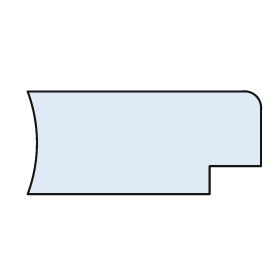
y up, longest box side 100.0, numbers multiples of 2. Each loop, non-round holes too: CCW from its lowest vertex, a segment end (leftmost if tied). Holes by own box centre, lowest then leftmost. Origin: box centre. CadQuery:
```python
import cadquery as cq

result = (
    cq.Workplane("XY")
    .moveTo(-50.0, -22.0)
    .lineTo(28.0, -22.0)
    .lineTo(28.0, -10.0)
    .lineTo(50.0, -10.0)
    .lineTo(50.0, 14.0)
    .threePointArc((48.0, 20.0), (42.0, 22.0))
    .lineTo(-50.0, 22.0)
    .threePointArc((-46.0, 0.0), (-50.0, -22.0))
    .close()
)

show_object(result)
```